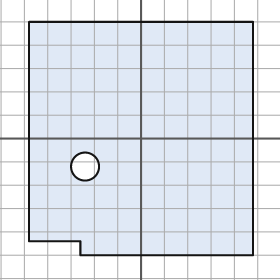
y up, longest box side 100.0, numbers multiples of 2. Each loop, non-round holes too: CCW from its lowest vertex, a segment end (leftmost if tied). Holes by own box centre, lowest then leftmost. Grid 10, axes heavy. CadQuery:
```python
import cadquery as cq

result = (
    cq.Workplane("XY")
    .moveTo(-26.0, -50.0)
    .lineTo(48.0, -50.0)
    .lineTo(48.0, 50.0)
    .lineTo(-48.0, 50.0)
    .lineTo(-48.0, -44.0)
    .lineTo(-26.0, -44.0)
    .close()
    .moveTo(-24.0, -12.0)
    .circle(6.0)
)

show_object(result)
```